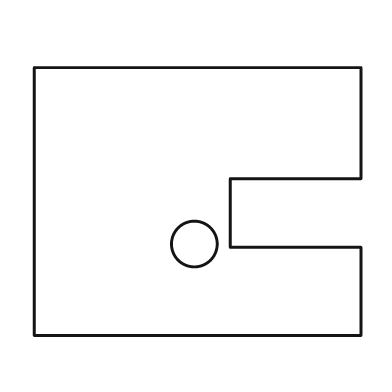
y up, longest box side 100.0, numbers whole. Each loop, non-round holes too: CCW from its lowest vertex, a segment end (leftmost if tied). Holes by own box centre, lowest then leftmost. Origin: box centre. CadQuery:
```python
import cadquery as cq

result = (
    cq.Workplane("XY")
    .moveTo(-50.0, -41.0)
    .lineTo(50.0, -41.0)
    .lineTo(50.0, -14.0)
    .lineTo(10.0, -14.0)
    .lineTo(10.0, 7.0)
    .lineTo(50.0, 7.0)
    .lineTo(50.0, 41.0)
    .lineTo(-50.0, 41.0)
    .close()
    .moveTo(-1.0, -13.0)
    .circle(7.0)
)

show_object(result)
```